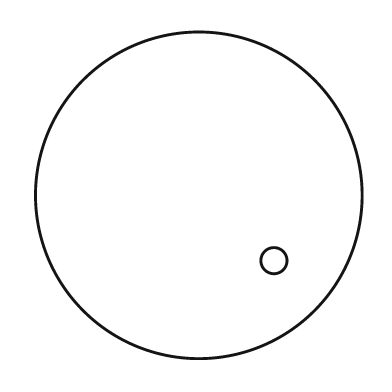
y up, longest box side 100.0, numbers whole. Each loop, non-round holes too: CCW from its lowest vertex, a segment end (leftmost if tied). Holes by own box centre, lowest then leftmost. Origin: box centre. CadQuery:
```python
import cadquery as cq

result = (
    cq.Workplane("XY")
    .moveTo(0.0, 0.0)
    .circle(50.0)
    .moveTo(23.0, -20.0)
    .circle(4.0)
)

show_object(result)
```